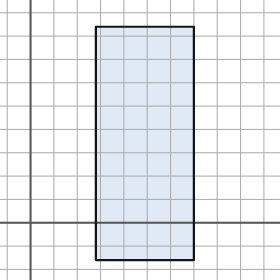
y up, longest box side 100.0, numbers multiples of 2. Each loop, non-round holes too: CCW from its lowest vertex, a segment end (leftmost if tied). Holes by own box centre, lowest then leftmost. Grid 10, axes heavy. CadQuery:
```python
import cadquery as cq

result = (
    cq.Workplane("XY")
    .moveTo(28.0, -16.0)
    .lineTo(70.0, -16.0)
    .lineTo(70.0, 84.0)
    .lineTo(28.0, 84.0)
    .close()
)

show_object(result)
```